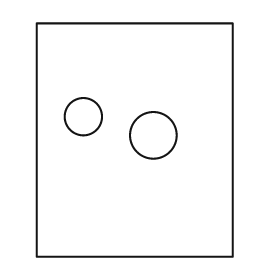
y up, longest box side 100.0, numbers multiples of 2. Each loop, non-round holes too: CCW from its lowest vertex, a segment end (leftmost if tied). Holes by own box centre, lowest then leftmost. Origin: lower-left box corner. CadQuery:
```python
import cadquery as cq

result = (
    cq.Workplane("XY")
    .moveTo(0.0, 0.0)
    .lineTo(84.0, 0.0)
    .lineTo(84.0, 100.0)
    .lineTo(0.0, 100.0)
    .close()
    .moveTo(50.0, 52.0)
    .circle(10.0)
    .moveTo(20.0, 60.0)
    .circle(8.0)
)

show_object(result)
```